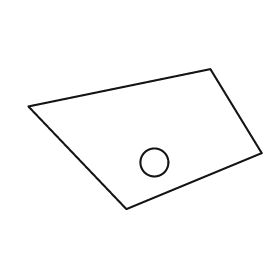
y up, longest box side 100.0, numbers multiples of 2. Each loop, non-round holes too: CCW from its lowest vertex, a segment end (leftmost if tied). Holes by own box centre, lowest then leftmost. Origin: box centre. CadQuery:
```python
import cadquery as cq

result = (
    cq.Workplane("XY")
    .moveTo(-8.0, -30.0)
    .lineTo(50.0, -6.0)
    .lineTo(28.0, 30.0)
    .lineTo(-50.0, 14.0)
    .close()
    .moveTo(4.0, -10.0)
    .circle(6.0)
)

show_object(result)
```